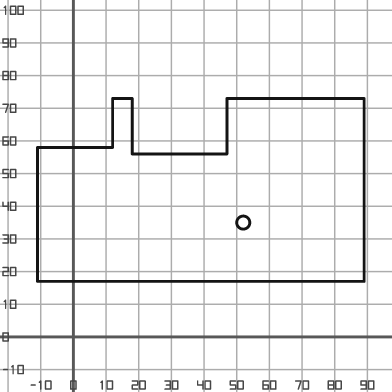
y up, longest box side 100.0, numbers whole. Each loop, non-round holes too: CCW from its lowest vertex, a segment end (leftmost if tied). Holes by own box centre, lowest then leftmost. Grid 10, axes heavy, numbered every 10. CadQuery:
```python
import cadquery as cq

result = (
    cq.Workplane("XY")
    .moveTo(-11.0, 17.0)
    .lineTo(89.0, 17.0)
    .lineTo(89.0, 73.0)
    .lineTo(47.0, 73.0)
    .lineTo(47.0, 56.0)
    .lineTo(18.0, 56.0)
    .lineTo(18.0, 73.0)
    .lineTo(12.0, 73.0)
    .lineTo(12.0, 58.0)
    .lineTo(-11.0, 58.0)
    .close()
    .moveTo(52.0, 35.0)
    .circle(2.0)
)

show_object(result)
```